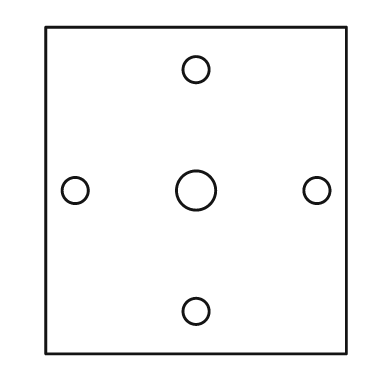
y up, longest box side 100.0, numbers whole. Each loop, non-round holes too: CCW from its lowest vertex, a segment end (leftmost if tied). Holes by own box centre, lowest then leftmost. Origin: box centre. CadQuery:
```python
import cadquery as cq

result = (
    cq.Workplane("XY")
    .moveTo(-46.0, -50.0)
    .lineTo(46.0, -50.0)
    .lineTo(46.0, 50.0)
    .lineTo(-46.0, 50.0)
    .close()
    .moveTo(0.0, -37.0)
    .circle(4.0)
    .moveTo(-37.0, 0.0)
    .circle(4.0)
    .moveTo(0.0, 0.0)
    .circle(6.0)
    .moveTo(37.0, 0.0)
    .circle(4.0)
    .moveTo(0.0, 37.0)
    .circle(4.0)
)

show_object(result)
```